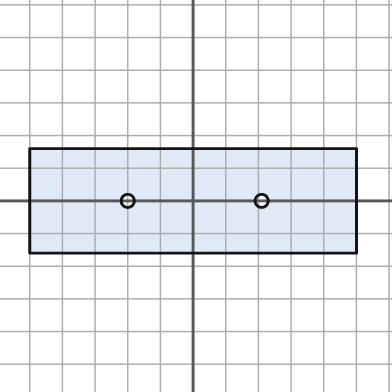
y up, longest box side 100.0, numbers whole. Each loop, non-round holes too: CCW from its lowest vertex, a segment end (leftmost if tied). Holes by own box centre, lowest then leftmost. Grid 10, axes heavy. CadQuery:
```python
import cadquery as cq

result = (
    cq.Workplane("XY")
    .moveTo(-50.0, -16.0)
    .lineTo(50.0, -16.0)
    .lineTo(50.0, 16.0)
    .lineTo(-50.0, 16.0)
    .close()
    .moveTo(-20.0, 0.0)
    .circle(2.0)
    .moveTo(21.0, 0.0)
    .circle(2.0)
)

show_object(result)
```